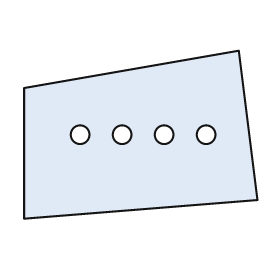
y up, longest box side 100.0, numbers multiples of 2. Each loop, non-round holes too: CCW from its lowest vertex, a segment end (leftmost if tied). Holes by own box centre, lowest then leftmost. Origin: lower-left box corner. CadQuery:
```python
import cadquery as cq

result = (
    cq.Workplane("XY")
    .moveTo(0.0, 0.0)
    .lineTo(100.0, 8.0)
    .lineTo(92.0, 72.0)
    .lineTo(0.0, 56.0)
    .close()
    .moveTo(24.0, 36.0)
    .circle(4.0)
    .moveTo(42.0, 36.0)
    .circle(4.0)
    .moveTo(60.0, 36.0)
    .circle(4.0)
    .moveTo(78.0, 36.0)
    .circle(4.0)
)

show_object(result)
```